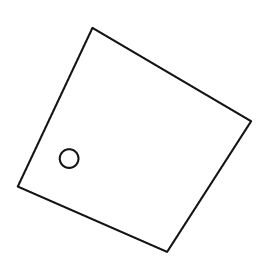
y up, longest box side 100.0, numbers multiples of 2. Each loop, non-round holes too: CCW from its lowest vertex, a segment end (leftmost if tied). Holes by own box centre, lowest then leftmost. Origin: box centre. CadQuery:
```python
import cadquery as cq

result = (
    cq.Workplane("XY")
    .moveTo(14.0, -48.0)
    .lineTo(50.0, 8.0)
    .lineTo(-18.0, 48.0)
    .lineTo(-50.0, -20.0)
    .close()
    .moveTo(-28.0, -8.0)
    .circle(4.0)
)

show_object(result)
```